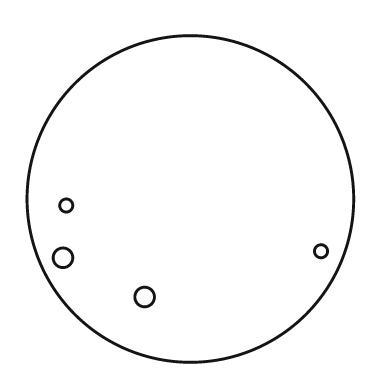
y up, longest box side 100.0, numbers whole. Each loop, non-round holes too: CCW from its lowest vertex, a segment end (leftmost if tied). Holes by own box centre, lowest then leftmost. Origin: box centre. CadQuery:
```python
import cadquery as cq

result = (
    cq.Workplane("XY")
    .moveTo(0.0, 0.0)
    .circle(50.0)
    .moveTo(-14.0, -30.0)
    .circle(3.0)
    .moveTo(-39.0, -18.0)
    .circle(3.0)
    .moveTo(40.0, -16.0)
    .circle(2.0)
    .moveTo(-38.0, -2.0)
    .circle(2.0)
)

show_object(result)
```